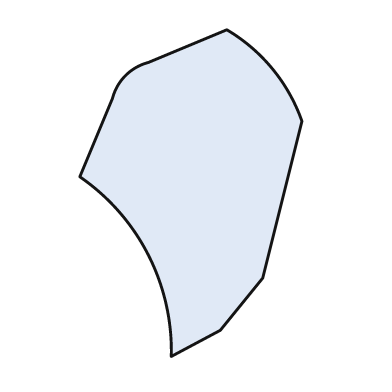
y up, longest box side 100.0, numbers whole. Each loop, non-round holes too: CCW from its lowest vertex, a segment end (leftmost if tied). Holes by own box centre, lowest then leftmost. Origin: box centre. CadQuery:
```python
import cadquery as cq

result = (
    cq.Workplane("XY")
    .moveTo(-6.0, -50.0)
    .lineTo(9.0, -42.0)
    .lineTo(22.0, -26.0)
    .lineTo(34.0, 22.0)
    .threePointArc((25.0, 38.0), (11.0, 50.0))
    .lineTo(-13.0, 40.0)
    .threePointArc((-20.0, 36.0), (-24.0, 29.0))
    .lineTo(-34.0, 5.0)
    .threePointArc((-13.0, -19.0), (-6.0, -50.0))
    .close()
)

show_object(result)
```